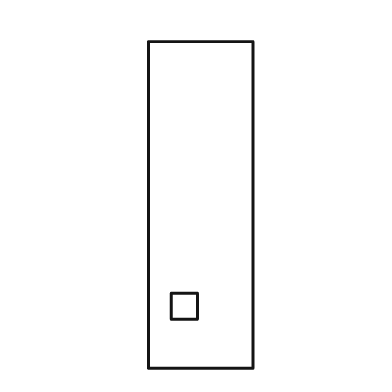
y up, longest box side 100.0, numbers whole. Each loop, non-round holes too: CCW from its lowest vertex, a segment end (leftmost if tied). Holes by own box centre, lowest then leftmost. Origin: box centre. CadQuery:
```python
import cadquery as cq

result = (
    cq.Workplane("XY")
    .moveTo(-16.0, -50.0)
    .lineTo(16.0, -50.0)
    .lineTo(16.0, 50.0)
    .lineTo(-16.0, 50.0)
    .close()
    .moveTo(-9.0, -35.0)
    .lineTo(-1.0, -35.0)
    .lineTo(-1.0, -27.0)
    .lineTo(-9.0, -27.0)
    .close()
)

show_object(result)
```